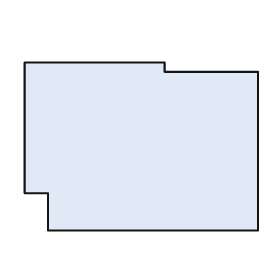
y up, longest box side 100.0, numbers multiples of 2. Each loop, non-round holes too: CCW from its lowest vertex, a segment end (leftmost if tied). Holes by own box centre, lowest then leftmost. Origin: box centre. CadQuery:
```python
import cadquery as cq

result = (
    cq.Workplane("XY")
    .moveTo(-40.0, -36.0)
    .lineTo(50.0, -36.0)
    .lineTo(50.0, 32.0)
    .lineTo(10.0, 32.0)
    .lineTo(10.0, 36.0)
    .lineTo(-50.0, 36.0)
    .lineTo(-50.0, -20.0)
    .lineTo(-40.0, -20.0)
    .close()
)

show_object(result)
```